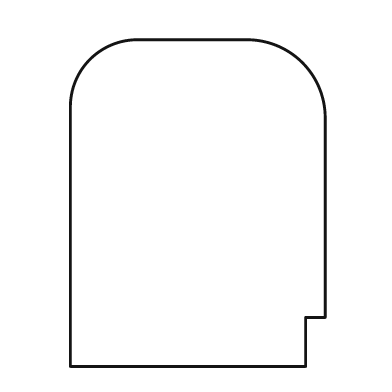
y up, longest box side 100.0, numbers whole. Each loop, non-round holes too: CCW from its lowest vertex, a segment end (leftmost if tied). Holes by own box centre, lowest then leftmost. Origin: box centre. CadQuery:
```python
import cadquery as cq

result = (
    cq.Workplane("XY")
    .moveTo(-39.0, -50.0)
    .lineTo(33.0, -50.0)
    .lineTo(33.0, -35.0)
    .lineTo(39.0, -35.0)
    .lineTo(39.0, 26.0)
    .threePointArc((32.0, 43.0), (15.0, 50.0))
    .lineTo(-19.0, 50.0)
    .threePointArc((-33.0, 44.0), (-39.0, 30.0))
    .close()
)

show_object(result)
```